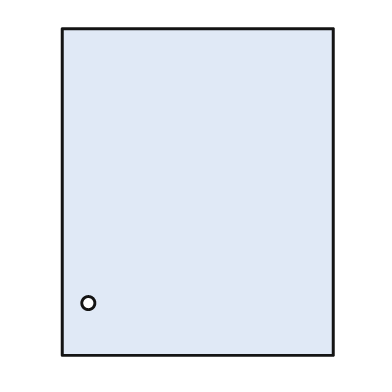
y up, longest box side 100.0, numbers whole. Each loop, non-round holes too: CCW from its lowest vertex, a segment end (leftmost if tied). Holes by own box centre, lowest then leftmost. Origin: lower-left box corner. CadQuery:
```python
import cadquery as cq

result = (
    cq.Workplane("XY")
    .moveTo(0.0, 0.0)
    .lineTo(83.0, 0.0)
    .lineTo(83.0, 100.0)
    .lineTo(0.0, 100.0)
    .close()
    .moveTo(8.0, 16.0)
    .circle(2.0)
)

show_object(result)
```